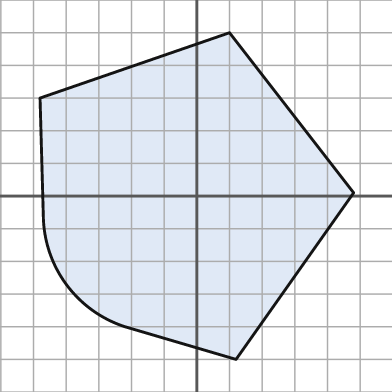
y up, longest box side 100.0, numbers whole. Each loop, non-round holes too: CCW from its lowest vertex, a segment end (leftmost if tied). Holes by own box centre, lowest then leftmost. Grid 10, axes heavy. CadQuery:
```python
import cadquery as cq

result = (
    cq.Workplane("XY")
    .moveTo(12.0, -50.0)
    .lineTo(48.0, 1.0)
    .lineTo(10.0, 50.0)
    .lineTo(-48.0, 30.0)
    .lineTo(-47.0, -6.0)
    .threePointArc((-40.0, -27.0), (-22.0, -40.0))
    .close()
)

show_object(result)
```